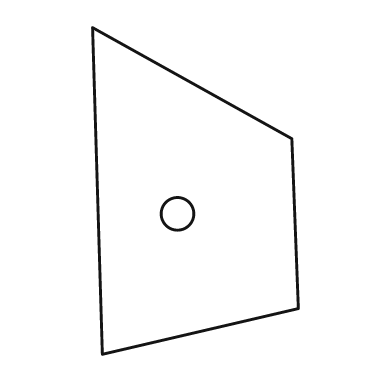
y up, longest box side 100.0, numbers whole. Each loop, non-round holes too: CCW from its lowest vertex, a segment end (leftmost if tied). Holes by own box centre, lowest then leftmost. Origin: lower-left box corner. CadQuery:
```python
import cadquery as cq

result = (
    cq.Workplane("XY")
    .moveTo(3.0, 0.0)
    .lineTo(63.0, 14.0)
    .lineTo(61.0, 66.0)
    .lineTo(0.0, 100.0)
    .close()
    .moveTo(26.0, 43.0)
    .circle(5.0)
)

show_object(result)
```